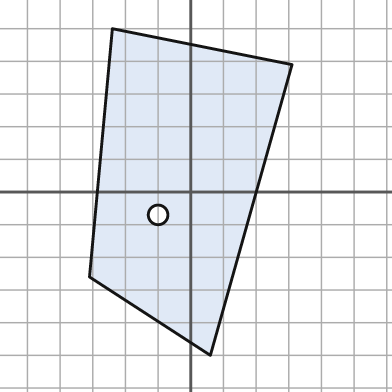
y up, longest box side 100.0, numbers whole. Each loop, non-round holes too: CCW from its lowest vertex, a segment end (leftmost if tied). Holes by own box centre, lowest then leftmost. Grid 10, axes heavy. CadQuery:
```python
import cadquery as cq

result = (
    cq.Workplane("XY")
    .moveTo(6.0, -50.0)
    .lineTo(31.0, 39.0)
    .lineTo(-24.0, 50.0)
    .lineTo(-31.0, -26.0)
    .close()
    .moveTo(-10.0, -7.0)
    .circle(3.0)
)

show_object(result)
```